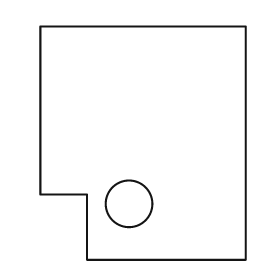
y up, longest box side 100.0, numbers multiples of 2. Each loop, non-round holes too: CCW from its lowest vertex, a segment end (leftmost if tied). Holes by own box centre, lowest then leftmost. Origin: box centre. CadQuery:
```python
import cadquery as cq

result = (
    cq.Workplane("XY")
    .moveTo(-24.0, -50.0)
    .lineTo(44.0, -50.0)
    .lineTo(44.0, 50.0)
    .lineTo(-44.0, 50.0)
    .lineTo(-44.0, -22.0)
    .lineTo(-24.0, -22.0)
    .close()
    .moveTo(-6.0, -26.0)
    .circle(10.0)
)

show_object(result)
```